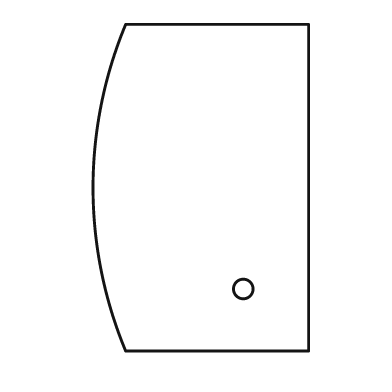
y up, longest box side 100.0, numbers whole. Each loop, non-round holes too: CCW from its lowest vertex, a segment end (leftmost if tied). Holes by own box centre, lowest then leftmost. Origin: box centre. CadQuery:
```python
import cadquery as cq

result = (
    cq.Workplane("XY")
    .moveTo(-23.0, -50.0)
    .lineTo(33.0, -50.0)
    .lineTo(33.0, 50.0)
    .lineTo(-23.0, 50.0)
    .threePointArc((-33.0, 0.0), (-23.0, -50.0))
    .close()
    .moveTo(13.0, -31.0)
    .circle(3.0)
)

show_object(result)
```